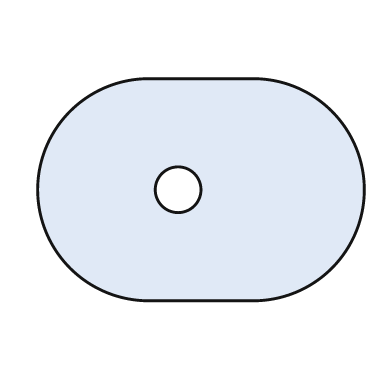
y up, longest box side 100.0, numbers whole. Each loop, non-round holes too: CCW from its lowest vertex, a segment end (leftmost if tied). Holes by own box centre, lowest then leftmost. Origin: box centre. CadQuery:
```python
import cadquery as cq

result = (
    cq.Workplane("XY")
    .moveTo(-16.0, -34.0)
    .lineTo(16.0, -34.0)
    .threePointArc((50.0, 0.0), (16.0, 34.0))
    .lineTo(-16.0, 34.0)
    .threePointArc((-50.0, 0.0), (-16.0, -34.0))
    .close()
    .moveTo(-7.0, 0.0)
    .circle(7.0)
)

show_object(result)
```